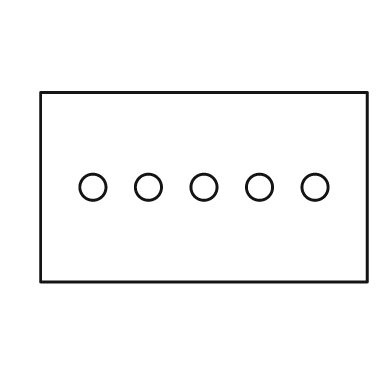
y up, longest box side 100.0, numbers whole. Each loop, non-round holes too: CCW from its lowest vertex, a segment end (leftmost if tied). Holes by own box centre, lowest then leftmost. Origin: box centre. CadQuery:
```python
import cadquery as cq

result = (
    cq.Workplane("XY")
    .moveTo(-50.0, -29.0)
    .lineTo(50.0, -29.0)
    .lineTo(50.0, 29.0)
    .lineTo(-50.0, 29.0)
    .close()
    .moveTo(-34.0, 0.0)
    .circle(4.0)
    .moveTo(-17.0, 0.0)
    .circle(4.0)
    .moveTo(0.0, 0.0)
    .circle(4.0)
    .moveTo(17.0, 0.0)
    .circle(4.0)
    .moveTo(34.0, 0.0)
    .circle(4.0)
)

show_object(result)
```